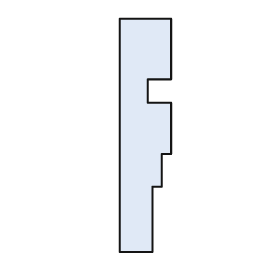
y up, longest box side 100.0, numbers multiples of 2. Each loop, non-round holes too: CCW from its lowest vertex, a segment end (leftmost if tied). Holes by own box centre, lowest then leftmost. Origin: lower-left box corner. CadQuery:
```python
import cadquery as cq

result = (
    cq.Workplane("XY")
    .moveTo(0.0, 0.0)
    .lineTo(14.0, 0.0)
    .lineTo(14.0, 28.0)
    .lineTo(18.0, 28.0)
    .lineTo(18.0, 42.0)
    .lineTo(22.0, 42.0)
    .lineTo(22.0, 64.0)
    .lineTo(12.0, 64.0)
    .lineTo(12.0, 74.0)
    .lineTo(22.0, 74.0)
    .lineTo(22.0, 100.0)
    .lineTo(0.0, 100.0)
    .close()
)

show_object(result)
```